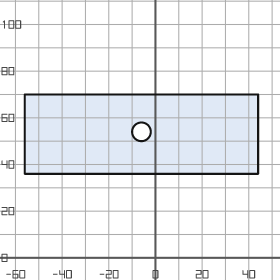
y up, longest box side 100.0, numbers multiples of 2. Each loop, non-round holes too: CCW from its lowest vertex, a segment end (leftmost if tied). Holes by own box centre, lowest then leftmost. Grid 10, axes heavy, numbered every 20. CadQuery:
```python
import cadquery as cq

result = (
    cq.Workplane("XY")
    .moveTo(-56.0, 36.0)
    .lineTo(44.0, 36.0)
    .lineTo(44.0, 70.0)
    .lineTo(-56.0, 70.0)
    .close()
    .moveTo(-6.0, 54.0)
    .circle(4.0)
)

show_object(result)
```